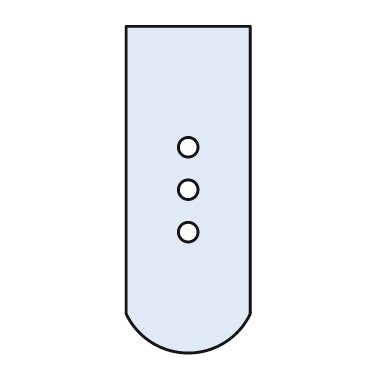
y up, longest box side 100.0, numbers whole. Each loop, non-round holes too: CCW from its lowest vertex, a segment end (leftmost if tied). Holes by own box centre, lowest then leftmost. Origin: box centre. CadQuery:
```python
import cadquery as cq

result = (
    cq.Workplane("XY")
    .moveTo(-19.0, -38.0)
    .threePointArc((0.0, -50.0), (19.0, -38.0))
    .lineTo(19.0, 50.0)
    .lineTo(-19.0, 50.0)
    .close()
    .moveTo(0.0, -13.0)
    .circle(3.0)
    .moveTo(0.0, 0.0)
    .circle(3.0)
    .moveTo(0.0, 13.0)
    .circle(3.0)
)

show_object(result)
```